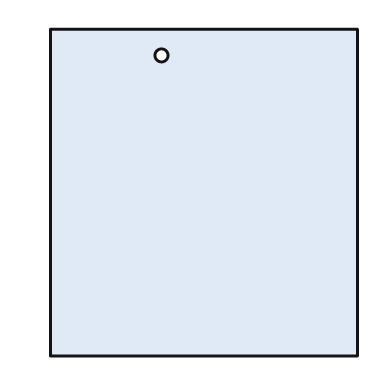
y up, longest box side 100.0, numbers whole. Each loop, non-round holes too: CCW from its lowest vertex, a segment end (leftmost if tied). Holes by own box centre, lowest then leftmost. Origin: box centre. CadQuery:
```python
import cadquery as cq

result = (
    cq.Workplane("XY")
    .moveTo(-47.0, -50.0)
    .lineTo(47.0, -50.0)
    .lineTo(47.0, 50.0)
    .lineTo(-47.0, 50.0)
    .close()
    .moveTo(-13.0, 42.0)
    .circle(2.0)
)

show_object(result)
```